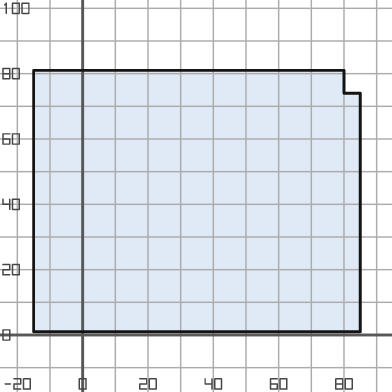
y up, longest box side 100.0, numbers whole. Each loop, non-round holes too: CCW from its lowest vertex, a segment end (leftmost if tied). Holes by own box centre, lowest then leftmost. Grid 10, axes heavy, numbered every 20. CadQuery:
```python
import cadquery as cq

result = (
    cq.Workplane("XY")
    .moveTo(-15.0, 1.0)
    .lineTo(85.0, 1.0)
    .lineTo(85.0, 74.0)
    .lineTo(80.0, 74.0)
    .lineTo(80.0, 81.0)
    .lineTo(-15.0, 81.0)
    .close()
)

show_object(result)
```